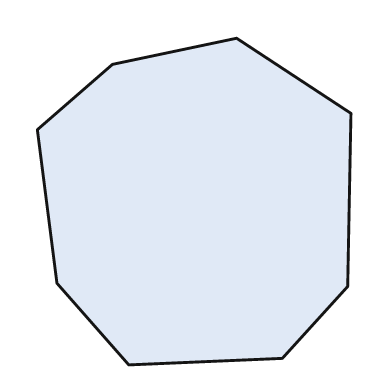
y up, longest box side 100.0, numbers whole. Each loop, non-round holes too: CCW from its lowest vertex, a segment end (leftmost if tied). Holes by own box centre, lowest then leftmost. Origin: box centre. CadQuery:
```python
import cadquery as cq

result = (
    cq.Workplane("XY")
    .moveTo(-20.0, -50.0)
    .lineTo(27.0, -48.0)
    .lineTo(47.0, -26.0)
    .lineTo(48.0, 27.0)
    .lineTo(13.0, 50.0)
    .lineTo(-25.0, 42.0)
    .lineTo(-48.0, 22.0)
    .lineTo(-42.0, -25.0)
    .close()
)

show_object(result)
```